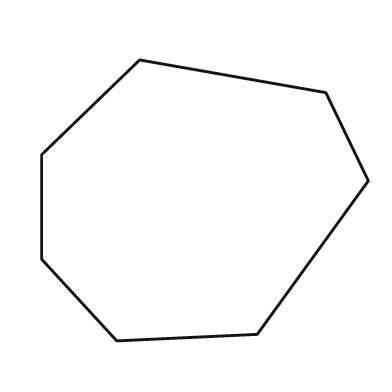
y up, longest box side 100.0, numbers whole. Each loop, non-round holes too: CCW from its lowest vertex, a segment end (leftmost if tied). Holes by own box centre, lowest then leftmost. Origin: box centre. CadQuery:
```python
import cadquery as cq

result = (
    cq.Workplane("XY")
    .moveTo(-27.0, -43.0)
    .lineTo(16.0, -41.0)
    .lineTo(50.0, 6.0)
    .lineTo(37.0, 33.0)
    .lineTo(-20.0, 43.0)
    .lineTo(-50.0, 14.0)
    .lineTo(-50.0, -18.0)
    .close()
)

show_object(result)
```